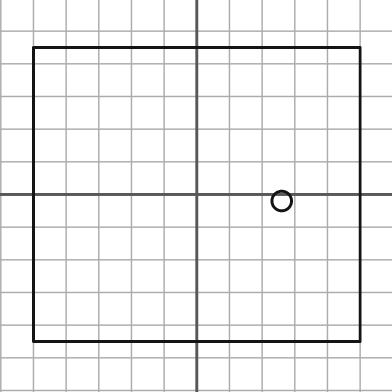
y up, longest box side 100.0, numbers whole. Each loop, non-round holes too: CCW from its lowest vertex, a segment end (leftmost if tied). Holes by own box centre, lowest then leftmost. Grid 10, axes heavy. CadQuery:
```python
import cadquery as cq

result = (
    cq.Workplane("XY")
    .moveTo(-50.0, -45.0)
    .lineTo(50.0, -45.0)
    .lineTo(50.0, 45.0)
    .lineTo(-50.0, 45.0)
    .close()
    .moveTo(26.0, -2.0)
    .circle(3.0)
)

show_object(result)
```